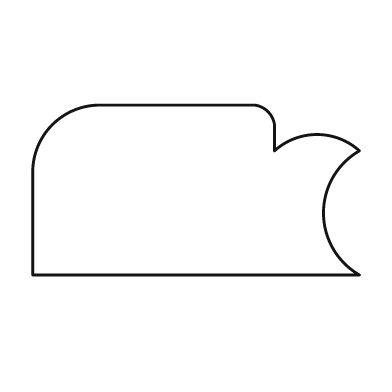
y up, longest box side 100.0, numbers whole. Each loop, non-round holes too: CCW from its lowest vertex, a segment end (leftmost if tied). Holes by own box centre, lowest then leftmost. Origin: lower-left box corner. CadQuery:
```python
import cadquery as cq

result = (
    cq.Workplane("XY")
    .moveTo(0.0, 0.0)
    .lineTo(100.0, 0.0)
    .threePointArc((89.0, 19.0), (100.0, 38.0))
    .threePointArc((87.0, 43.0), (74.0, 38.0))
    .lineTo(74.0, 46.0)
    .threePointArc((72.0, 50.0), (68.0, 52.0))
    .lineTo(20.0, 52.0)
    .threePointArc((6.0, 46.0), (0.0, 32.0))
    .close()
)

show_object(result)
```